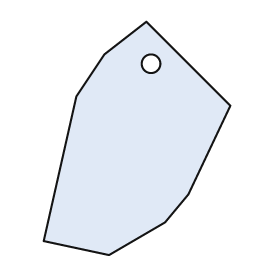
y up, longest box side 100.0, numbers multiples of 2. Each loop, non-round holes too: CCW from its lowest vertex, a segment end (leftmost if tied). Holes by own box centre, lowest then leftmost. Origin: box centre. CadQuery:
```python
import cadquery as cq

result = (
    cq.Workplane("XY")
    .moveTo(-12.0, -50.0)
    .lineTo(12.0, -36.0)
    .lineTo(22.0, -24.0)
    .lineTo(40.0, 14.0)
    .lineTo(4.0, 50.0)
    .lineTo(-14.0, 36.0)
    .lineTo(-26.0, 18.0)
    .lineTo(-40.0, -44.0)
    .close()
    .moveTo(6.0, 32.0)
    .circle(4.0)
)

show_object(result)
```